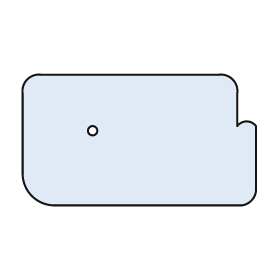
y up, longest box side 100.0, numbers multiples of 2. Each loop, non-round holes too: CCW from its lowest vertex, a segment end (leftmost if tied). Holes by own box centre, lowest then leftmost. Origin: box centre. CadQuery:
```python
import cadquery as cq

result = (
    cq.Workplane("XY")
    .moveTo(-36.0, -28.0)
    .lineTo(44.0, -28.0)
    .threePointArc((48.0, -26.0), (50.0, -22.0))
    .lineTo(50.0, 6.0)
    .threePointArc((46.0, 8.0), (42.0, 6.0))
    .lineTo(42.0, 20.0)
    .threePointArc((40.0, 26.0), (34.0, 28.0))
    .lineTo(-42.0, 28.0)
    .threePointArc((-48.0, 26.0), (-50.0, 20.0))
    .lineTo(-50.0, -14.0)
    .threePointArc((-46.0, -24.0), (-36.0, -28.0))
    .close()
    .moveTo(-20.0, 4.0)
    .circle(2.0)
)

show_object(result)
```